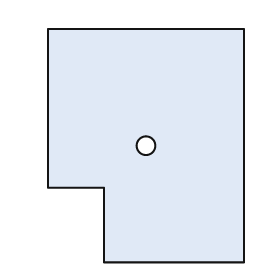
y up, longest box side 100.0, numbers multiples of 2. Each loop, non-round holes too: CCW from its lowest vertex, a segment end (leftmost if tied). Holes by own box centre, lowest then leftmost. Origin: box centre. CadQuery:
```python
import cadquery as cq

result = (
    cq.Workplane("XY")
    .moveTo(-18.0, -50.0)
    .lineTo(42.0, -50.0)
    .lineTo(42.0, 50.0)
    .lineTo(-42.0, 50.0)
    .lineTo(-42.0, -18.0)
    .lineTo(-18.0, -18.0)
    .close()
    .moveTo(0.0, 0.0)
    .circle(4.0)
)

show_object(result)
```